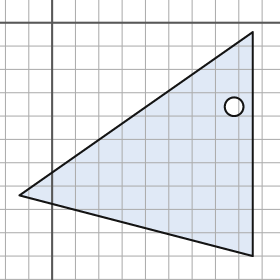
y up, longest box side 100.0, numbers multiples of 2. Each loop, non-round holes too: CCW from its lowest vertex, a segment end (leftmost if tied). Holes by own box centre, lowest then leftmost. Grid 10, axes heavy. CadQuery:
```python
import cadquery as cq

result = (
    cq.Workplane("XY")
    .moveTo(86.0, -100.0)
    .lineTo(86.0, -4.0)
    .lineTo(-14.0, -74.0)
    .close()
    .moveTo(78.0, -36.0)
    .circle(4.0)
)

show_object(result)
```